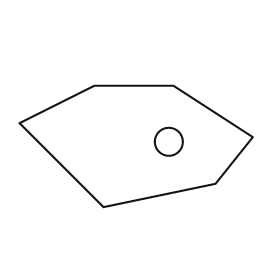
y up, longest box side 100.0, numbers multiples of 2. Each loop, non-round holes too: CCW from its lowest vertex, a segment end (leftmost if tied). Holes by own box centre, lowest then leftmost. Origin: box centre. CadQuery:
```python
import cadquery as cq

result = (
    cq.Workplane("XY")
    .moveTo(-14.0, -26.0)
    .lineTo(34.0, -16.0)
    .lineTo(50.0, 4.0)
    .lineTo(16.0, 26.0)
    .lineTo(-18.0, 26.0)
    .lineTo(-50.0, 10.0)
    .close()
    .moveTo(14.0, 2.0)
    .circle(6.0)
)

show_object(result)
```